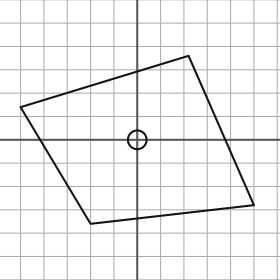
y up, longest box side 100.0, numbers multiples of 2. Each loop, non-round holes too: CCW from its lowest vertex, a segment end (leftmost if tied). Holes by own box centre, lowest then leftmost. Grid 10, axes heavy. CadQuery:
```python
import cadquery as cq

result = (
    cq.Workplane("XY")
    .moveTo(-20.0, -36.0)
    .lineTo(50.0, -28.0)
    .lineTo(22.0, 36.0)
    .lineTo(-50.0, 14.0)
    .close()
    .moveTo(0.0, 0.0)
    .circle(4.0)
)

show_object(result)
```